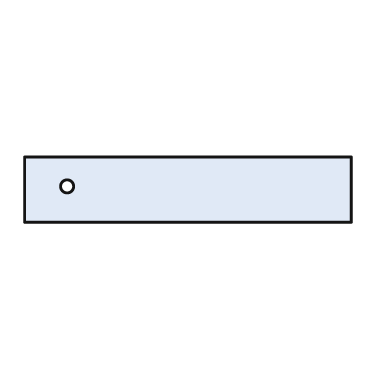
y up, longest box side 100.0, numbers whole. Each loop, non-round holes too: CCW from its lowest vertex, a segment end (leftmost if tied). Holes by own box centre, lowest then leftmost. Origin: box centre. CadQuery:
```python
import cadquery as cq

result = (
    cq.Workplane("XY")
    .moveTo(-50.0, -10.0)
    .lineTo(50.0, -10.0)
    .lineTo(50.0, 10.0)
    .lineTo(-50.0, 10.0)
    .close()
    .moveTo(-37.0, 1.0)
    .circle(2.0)
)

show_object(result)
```